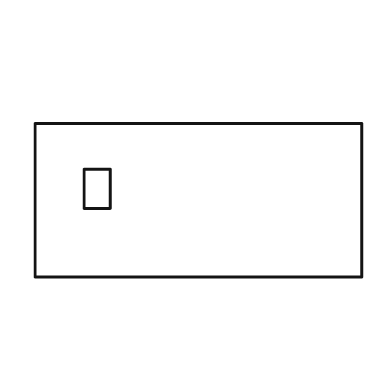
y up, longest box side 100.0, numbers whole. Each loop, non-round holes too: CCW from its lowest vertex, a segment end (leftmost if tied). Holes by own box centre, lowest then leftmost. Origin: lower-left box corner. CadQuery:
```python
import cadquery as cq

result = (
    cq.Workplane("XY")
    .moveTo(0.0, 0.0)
    .lineTo(100.0, 0.0)
    .lineTo(100.0, 47.0)
    .lineTo(0.0, 47.0)
    .close()
    .moveTo(15.0, 21.0)
    .lineTo(23.0, 21.0)
    .lineTo(23.0, 33.0)
    .lineTo(15.0, 33.0)
    .close()
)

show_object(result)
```